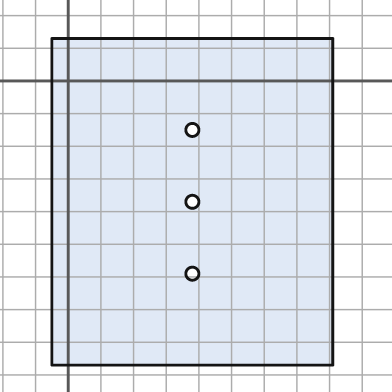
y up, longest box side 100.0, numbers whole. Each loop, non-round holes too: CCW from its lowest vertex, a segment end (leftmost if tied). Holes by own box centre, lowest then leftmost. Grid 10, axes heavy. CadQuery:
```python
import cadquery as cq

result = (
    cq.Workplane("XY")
    .moveTo(-5.0, -87.0)
    .lineTo(81.0, -87.0)
    .lineTo(81.0, 13.0)
    .lineTo(-5.0, 13.0)
    .close()
    .moveTo(38.0, -59.0)
    .circle(2.0)
    .moveTo(38.0, -37.0)
    .circle(2.0)
    .moveTo(38.0, -15.0)
    .circle(2.0)
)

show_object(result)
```